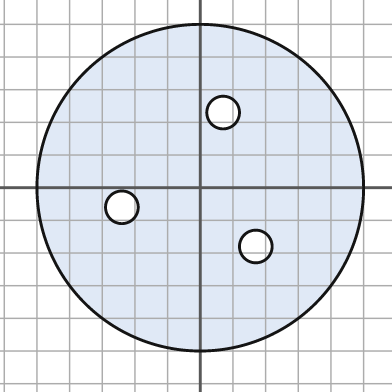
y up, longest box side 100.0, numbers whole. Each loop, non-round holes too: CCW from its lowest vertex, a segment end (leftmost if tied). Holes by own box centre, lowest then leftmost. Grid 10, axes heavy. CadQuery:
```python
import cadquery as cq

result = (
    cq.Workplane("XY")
    .moveTo(0.0, 0.0)
    .circle(50.0)
    .moveTo(17.0, -18.0)
    .circle(5.0)
    .moveTo(-24.0, -6.0)
    .circle(5.0)
    .moveTo(7.0, 23.0)
    .circle(5.0)
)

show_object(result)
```